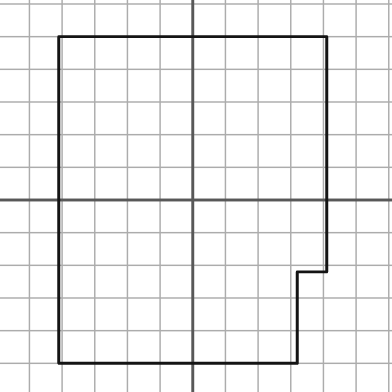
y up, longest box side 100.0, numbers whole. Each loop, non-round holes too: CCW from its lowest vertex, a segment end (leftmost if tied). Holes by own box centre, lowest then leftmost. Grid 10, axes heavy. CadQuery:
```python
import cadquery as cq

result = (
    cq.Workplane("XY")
    .moveTo(-41.0, -50.0)
    .lineTo(32.0, -50.0)
    .lineTo(32.0, -22.0)
    .lineTo(41.0, -22.0)
    .lineTo(41.0, 50.0)
    .lineTo(-41.0, 50.0)
    .close()
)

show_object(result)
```